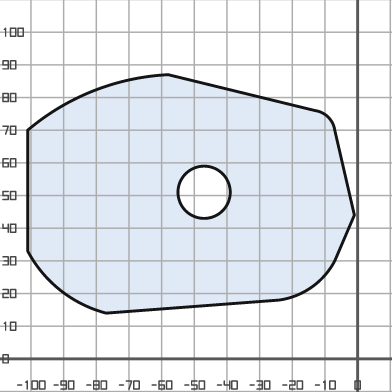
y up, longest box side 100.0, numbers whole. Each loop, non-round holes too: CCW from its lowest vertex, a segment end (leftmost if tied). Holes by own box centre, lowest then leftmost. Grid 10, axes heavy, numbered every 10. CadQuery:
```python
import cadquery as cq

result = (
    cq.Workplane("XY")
    .moveTo(-77.0, 14.0)
    .lineTo(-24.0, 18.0)
    .threePointArc((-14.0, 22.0), (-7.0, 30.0))
    .lineTo(-1.0, 44.0)
    .lineTo(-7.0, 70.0)
    .threePointArc((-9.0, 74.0), (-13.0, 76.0))
    .lineTo(-58.0, 87.0)
    .threePointArc((-81.0, 82.0), (-101.0, 70.0))
    .lineTo(-101.0, 33.0)
    .threePointArc((-91.0, 21.0), (-77.0, 14.0))
    .close()
    .moveTo(-47.0, 51.0)
    .circle(8.0)
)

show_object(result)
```